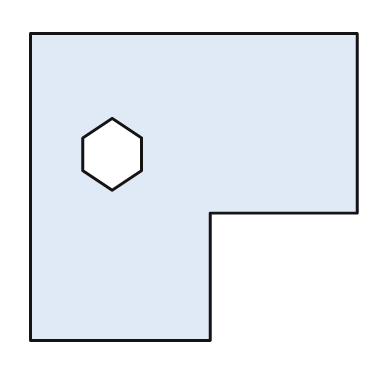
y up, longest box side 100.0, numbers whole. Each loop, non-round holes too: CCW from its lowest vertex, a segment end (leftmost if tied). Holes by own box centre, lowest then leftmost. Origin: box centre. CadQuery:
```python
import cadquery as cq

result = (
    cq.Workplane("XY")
    .moveTo(-50.0, -47.0)
    .lineTo(5.0, -47.0)
    .lineTo(5.0, -8.0)
    .lineTo(50.0, -8.0)
    .lineTo(50.0, 47.0)
    .lineTo(-50.0, 47.0)
    .close()
    .moveTo(-25.0, -1.0)
    .lineTo(-16.0, 5.0)
    .lineTo(-16.0, 15.0)
    .lineTo(-25.0, 21.0)
    .lineTo(-34.0, 15.0)
    .lineTo(-34.0, 5.0)
    .close()
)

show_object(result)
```